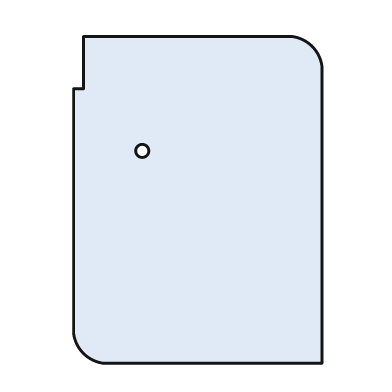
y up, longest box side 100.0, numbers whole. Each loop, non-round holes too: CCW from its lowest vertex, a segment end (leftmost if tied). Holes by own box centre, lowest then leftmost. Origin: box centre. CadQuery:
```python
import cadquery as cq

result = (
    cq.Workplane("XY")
    .moveTo(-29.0, -50.0)
    .lineTo(38.0, -50.0)
    .lineTo(38.0, 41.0)
    .threePointArc((35.0, 47.0), (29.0, 50.0))
    .lineTo(-35.0, 50.0)
    .lineTo(-35.0, 34.0)
    .lineTo(-38.0, 34.0)
    .lineTo(-38.0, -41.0)
    .threePointArc((-35.0, -47.0), (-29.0, -50.0))
    .close()
    .moveTo(-17.0, 15.0)
    .circle(2.0)
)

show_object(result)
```